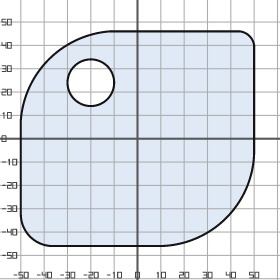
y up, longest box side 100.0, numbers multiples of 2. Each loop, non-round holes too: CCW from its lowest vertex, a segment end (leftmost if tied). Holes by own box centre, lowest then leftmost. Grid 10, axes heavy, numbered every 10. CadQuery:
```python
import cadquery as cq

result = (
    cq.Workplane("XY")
    .moveTo(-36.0, -46.0)
    .lineTo(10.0, -46.0)
    .threePointArc((38.0, -34.0), (50.0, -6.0))
    .lineTo(50.0, 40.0)
    .threePointArc((48.0, 44.0), (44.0, 46.0))
    .lineTo(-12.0, 46.0)
    .threePointArc((-38.0, 34.0), (-50.0, 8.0))
    .lineTo(-50.0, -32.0)
    .threePointArc((-46.0, -42.0), (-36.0, -46.0))
    .close()
    .moveTo(-20.0, 24.0)
    .circle(10.0)
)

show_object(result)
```